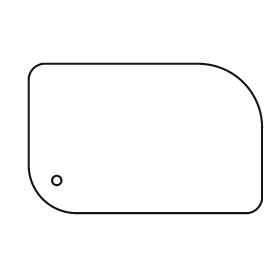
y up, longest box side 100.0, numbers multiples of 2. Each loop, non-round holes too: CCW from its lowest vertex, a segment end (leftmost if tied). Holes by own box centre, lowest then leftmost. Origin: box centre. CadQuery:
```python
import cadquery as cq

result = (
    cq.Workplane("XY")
    .moveTo(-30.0, -32.0)
    .lineTo(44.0, -32.0)
    .threePointArc((48.0, -30.0), (50.0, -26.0))
    .lineTo(50.0, 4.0)
    .threePointArc((42.0, 24.0), (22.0, 32.0))
    .lineTo(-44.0, 32.0)
    .threePointArc((-48.0, 30.0), (-50.0, 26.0))
    .lineTo(-50.0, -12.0)
    .threePointArc((-44.0, -26.0), (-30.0, -32.0))
    .close()
    .moveTo(-38.0, -18.0)
    .circle(2.0)
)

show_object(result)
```